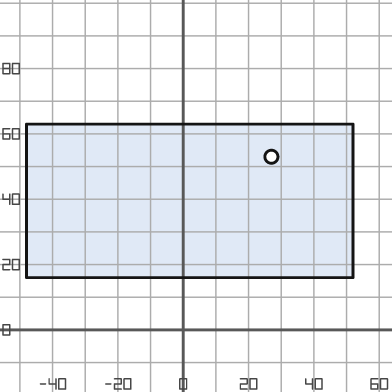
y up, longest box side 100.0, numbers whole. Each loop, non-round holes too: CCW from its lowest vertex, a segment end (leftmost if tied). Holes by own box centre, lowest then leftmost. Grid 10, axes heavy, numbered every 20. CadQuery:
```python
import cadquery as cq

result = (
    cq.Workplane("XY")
    .moveTo(-48.0, 16.0)
    .lineTo(52.0, 16.0)
    .lineTo(52.0, 63.0)
    .lineTo(-48.0, 63.0)
    .close()
    .moveTo(27.0, 53.0)
    .circle(2.0)
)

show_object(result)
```